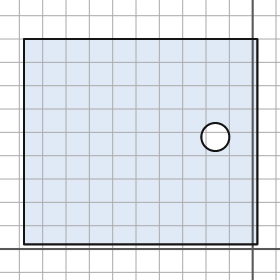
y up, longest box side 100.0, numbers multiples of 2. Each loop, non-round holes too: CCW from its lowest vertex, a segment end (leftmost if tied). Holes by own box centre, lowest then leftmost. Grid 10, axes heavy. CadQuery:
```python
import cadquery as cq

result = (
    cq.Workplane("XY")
    .moveTo(-98.0, 2.0)
    .lineTo(2.0, 2.0)
    .lineTo(2.0, 90.0)
    .lineTo(-98.0, 90.0)
    .close()
    .moveTo(-16.0, 48.0)
    .circle(6.0)
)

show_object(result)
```